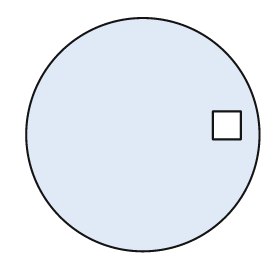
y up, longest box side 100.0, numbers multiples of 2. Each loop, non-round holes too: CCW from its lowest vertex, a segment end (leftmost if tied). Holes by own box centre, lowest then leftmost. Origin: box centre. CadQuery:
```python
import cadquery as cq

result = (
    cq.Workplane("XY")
    .moveTo(0.0, 0.0)
    .circle(50.0)
    .moveTo(30.0, -2.0)
    .lineTo(42.0, -2.0)
    .lineTo(42.0, 10.0)
    .lineTo(30.0, 10.0)
    .close()
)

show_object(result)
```